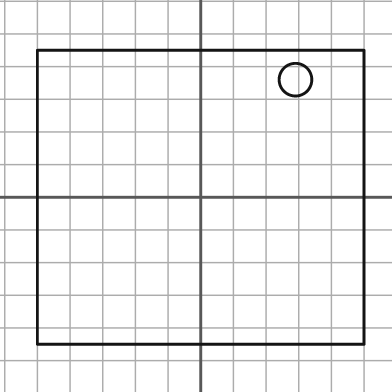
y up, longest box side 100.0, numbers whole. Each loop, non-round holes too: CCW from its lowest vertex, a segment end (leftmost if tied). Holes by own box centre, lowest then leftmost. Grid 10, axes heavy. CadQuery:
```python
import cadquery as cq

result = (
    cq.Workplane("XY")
    .moveTo(-50.0, -45.0)
    .lineTo(50.0, -45.0)
    .lineTo(50.0, 45.0)
    .lineTo(-50.0, 45.0)
    .close()
    .moveTo(29.0, 36.0)
    .circle(5.0)
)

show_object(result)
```